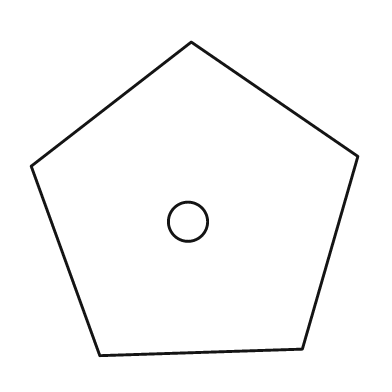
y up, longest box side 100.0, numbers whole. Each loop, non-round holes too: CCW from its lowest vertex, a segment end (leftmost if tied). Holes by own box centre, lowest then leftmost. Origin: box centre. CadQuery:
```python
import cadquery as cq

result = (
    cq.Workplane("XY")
    .moveTo(-29.0, -48.0)
    .lineTo(33.0, -46.0)
    .lineTo(50.0, 13.0)
    .lineTo(-1.0, 48.0)
    .lineTo(-50.0, 10.0)
    .close()
    .moveTo(-2.0, -7.0)
    .circle(6.0)
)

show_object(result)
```